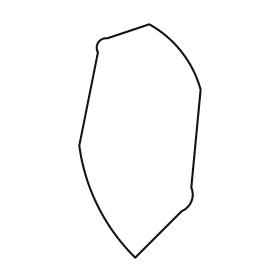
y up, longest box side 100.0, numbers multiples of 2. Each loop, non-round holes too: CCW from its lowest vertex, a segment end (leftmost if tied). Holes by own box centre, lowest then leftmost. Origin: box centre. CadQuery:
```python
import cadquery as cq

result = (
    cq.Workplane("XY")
    .moveTo(-2.0, -50.0)
    .lineTo(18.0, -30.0)
    .threePointArc((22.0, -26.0), (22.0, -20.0))
    .lineTo(26.0, 22.0)
    .threePointArc((18.0, 38.0), (4.0, 50.0))
    .lineTo(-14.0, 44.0)
    .threePointArc((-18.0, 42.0), (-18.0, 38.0))
    .lineTo(-26.0, -2.0)
    .threePointArc((-18.0, -28.0), (-2.0, -50.0))
    .close()
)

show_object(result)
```